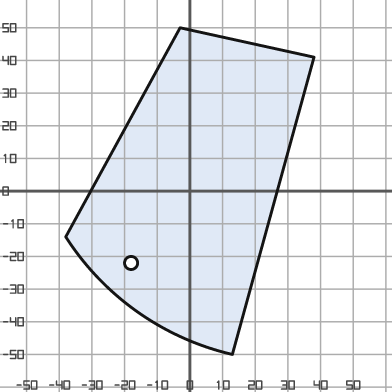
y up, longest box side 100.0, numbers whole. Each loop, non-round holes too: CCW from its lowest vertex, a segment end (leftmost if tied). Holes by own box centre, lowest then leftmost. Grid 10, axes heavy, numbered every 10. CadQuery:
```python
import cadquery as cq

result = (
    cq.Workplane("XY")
    .moveTo(13.0, -50.0)
    .lineTo(38.0, 41.0)
    .lineTo(-3.0, 50.0)
    .lineTo(-38.0, -14.0)
    .threePointArc((-16.0, -37.0), (13.0, -50.0))
    .close()
    .moveTo(-18.0, -22.0)
    .circle(2.0)
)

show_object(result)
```